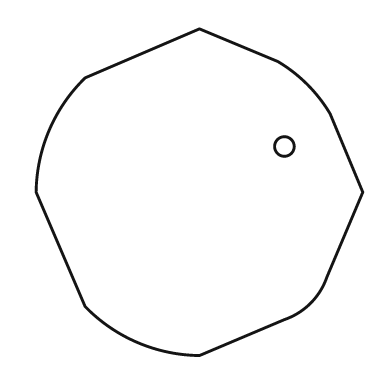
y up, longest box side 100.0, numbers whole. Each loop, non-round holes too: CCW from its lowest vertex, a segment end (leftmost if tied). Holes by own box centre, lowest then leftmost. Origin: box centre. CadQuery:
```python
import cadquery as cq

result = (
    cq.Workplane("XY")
    .moveTo(0.0, -50.0)
    .lineTo(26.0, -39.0)
    .threePointArc((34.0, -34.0), (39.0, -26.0))
    .lineTo(50.0, 0.0)
    .lineTo(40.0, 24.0)
    .threePointArc((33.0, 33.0), (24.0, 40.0))
    .lineTo(0.0, 50.0)
    .lineTo(-35.0, 35.0)
    .threePointArc((-46.0, 19.0), (-50.0, 0.0))
    .lineTo(-35.0, -35.0)
    .threePointArc((-19.0, -46.0), (0.0, -50.0))
    .close()
    .moveTo(26.0, 14.0)
    .circle(3.0)
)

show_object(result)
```